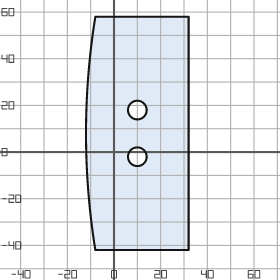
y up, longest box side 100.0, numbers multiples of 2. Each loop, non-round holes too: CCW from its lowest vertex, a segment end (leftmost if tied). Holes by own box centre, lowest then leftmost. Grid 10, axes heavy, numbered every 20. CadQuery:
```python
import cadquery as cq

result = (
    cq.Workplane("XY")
    .moveTo(-8.0, -42.0)
    .lineTo(32.0, -42.0)
    .lineTo(32.0, 58.0)
    .lineTo(-8.0, 58.0)
    .threePointArc((-12.0, 8.0), (-8.0, -42.0))
    .close()
    .moveTo(10.0, -2.0)
    .circle(4.0)
    .moveTo(10.0, 18.0)
    .circle(4.0)
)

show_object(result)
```